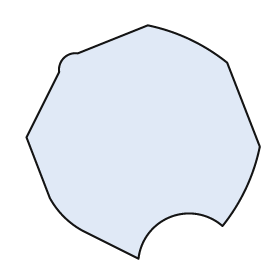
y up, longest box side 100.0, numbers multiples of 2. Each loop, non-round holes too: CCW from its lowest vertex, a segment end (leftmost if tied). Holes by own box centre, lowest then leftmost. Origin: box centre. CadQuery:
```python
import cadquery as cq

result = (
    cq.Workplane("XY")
    .moveTo(-2.0, -50.0)
    .threePointArc((12.0, -32.0), (34.0, -36.0))
    .threePointArc((44.0, -20.0), (50.0, -2.0))
    .lineTo(36.0, 34.0)
    .threePointArc((20.0, 44.0), (2.0, 50.0))
    .lineTo(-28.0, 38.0)
    .threePointArc((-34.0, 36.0), (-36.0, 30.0))
    .lineTo(-50.0, 2.0)
    .lineTo(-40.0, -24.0)
    .threePointArc((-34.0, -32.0), (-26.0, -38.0))
    .close()
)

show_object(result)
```